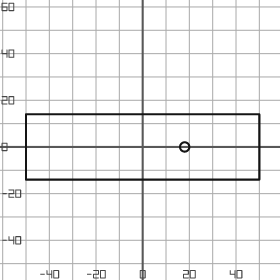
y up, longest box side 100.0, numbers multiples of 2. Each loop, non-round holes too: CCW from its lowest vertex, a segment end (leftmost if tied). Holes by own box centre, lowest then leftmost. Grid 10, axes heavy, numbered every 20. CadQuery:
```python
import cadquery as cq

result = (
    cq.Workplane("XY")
    .moveTo(-50.0, -14.0)
    .lineTo(50.0, -14.0)
    .lineTo(50.0, 14.0)
    .lineTo(-50.0, 14.0)
    .close()
    .moveTo(18.0, 0.0)
    .circle(2.0)
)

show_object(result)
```